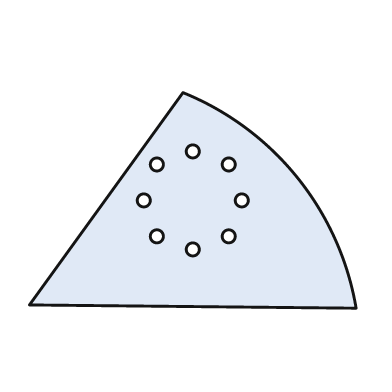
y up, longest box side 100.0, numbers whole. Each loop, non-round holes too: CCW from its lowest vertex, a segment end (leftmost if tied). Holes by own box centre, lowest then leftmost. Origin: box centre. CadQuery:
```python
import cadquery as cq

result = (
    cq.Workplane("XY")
    .moveTo(50.0, -33.0)
    .threePointArc((32.0, 7.0), (-3.0, 33.0))
    .lineTo(-50.0, -32.0)
    .close()
    .moveTo(0.0, -15.0)
    .circle(2.0)
    .moveTo(-11.0, -11.0)
    .circle(2.0)
    .moveTo(11.0, -11.0)
    .circle(2.0)
    .moveTo(-15.0, 0.0)
    .circle(2.0)
    .moveTo(15.0, 0.0)
    .circle(2.0)
    .moveTo(-11.0, 11.0)
    .circle(2.0)
    .moveTo(11.0, 11.0)
    .circle(2.0)
    .moveTo(0.0, 15.0)
    .circle(2.0)
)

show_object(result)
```